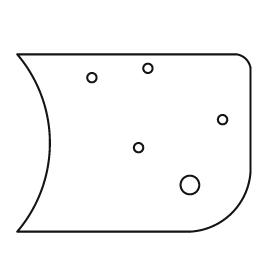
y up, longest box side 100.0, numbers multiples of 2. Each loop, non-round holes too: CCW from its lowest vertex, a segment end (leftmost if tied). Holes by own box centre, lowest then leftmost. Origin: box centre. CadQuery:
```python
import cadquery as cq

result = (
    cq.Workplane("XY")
    .moveTo(-50.0, -38.0)
    .lineTo(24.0, -38.0)
    .threePointArc((42.0, -30.0), (50.0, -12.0))
    .lineTo(50.0, 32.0)
    .threePointArc((48.0, 36.0), (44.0, 38.0))
    .lineTo(-50.0, 38.0)
    .threePointArc((-36.0, 0.0), (-50.0, -38.0))
    .close()
    .moveTo(24.0, -18.0)
    .circle(4.0)
    .moveTo(2.0, -2.0)
    .circle(2.0)
    .moveTo(38.0, 10.0)
    .circle(2.0)
    .moveTo(-18.0, 28.0)
    .circle(2.0)
    .moveTo(6.0, 32.0)
    .circle(2.0)
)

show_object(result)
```